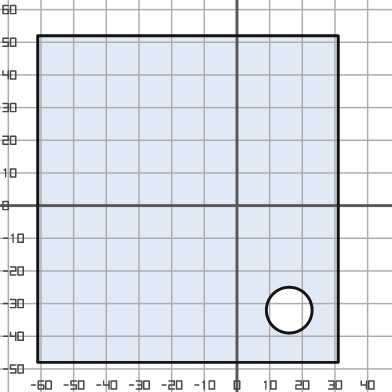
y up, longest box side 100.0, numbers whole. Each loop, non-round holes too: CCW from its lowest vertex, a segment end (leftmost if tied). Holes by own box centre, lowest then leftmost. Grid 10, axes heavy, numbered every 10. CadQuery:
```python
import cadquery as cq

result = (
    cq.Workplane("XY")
    .moveTo(-61.0, -48.0)
    .lineTo(31.0, -48.0)
    .lineTo(31.0, 52.0)
    .lineTo(-61.0, 52.0)
    .close()
    .moveTo(16.0, -32.0)
    .circle(7.0)
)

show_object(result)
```